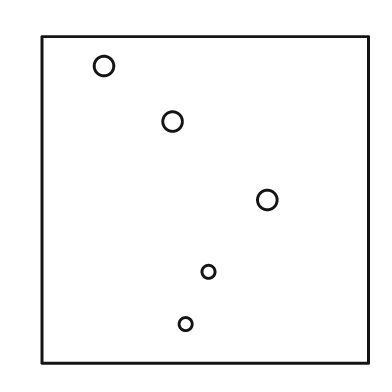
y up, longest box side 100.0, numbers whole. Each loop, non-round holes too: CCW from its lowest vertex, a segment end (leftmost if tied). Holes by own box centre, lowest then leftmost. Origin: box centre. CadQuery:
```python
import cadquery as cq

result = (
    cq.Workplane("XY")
    .moveTo(-50.0, -50.0)
    .lineTo(50.0, -50.0)
    .lineTo(50.0, 50.0)
    .lineTo(-50.0, 50.0)
    .close()
    .moveTo(-6.0, -38.0)
    .circle(2.0)
    .moveTo(1.0, -22.0)
    .circle(2.0)
    .moveTo(19.0, 0.0)
    .circle(3.0)
    .moveTo(-10.0, 24.0)
    .circle(3.0)
    .moveTo(-31.0, 41.0)
    .circle(3.0)
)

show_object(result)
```